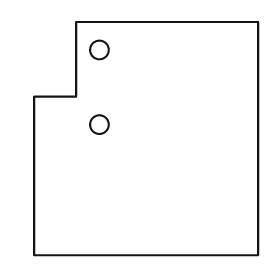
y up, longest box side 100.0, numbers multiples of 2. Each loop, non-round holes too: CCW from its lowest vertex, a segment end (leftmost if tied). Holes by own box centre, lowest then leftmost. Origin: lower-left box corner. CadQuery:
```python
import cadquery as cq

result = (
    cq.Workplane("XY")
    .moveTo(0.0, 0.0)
    .lineTo(96.0, 0.0)
    .lineTo(96.0, 100.0)
    .lineTo(18.0, 100.0)
    .lineTo(18.0, 68.0)
    .lineTo(0.0, 68.0)
    .close()
    .moveTo(28.0, 56.0)
    .circle(4.0)
    .moveTo(28.0, 88.0)
    .circle(4.0)
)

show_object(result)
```